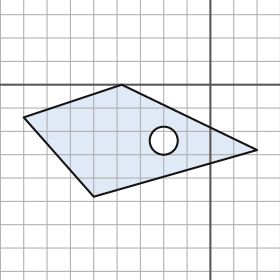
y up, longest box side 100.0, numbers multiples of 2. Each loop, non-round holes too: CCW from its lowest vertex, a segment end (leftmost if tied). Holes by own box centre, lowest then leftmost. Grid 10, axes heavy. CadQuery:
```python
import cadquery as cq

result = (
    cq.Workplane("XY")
    .moveTo(-50.0, -48.0)
    .lineTo(20.0, -28.0)
    .lineTo(-38.0, 0.0)
    .lineTo(-80.0, -14.0)
    .close()
    .moveTo(-20.0, -24.0)
    .circle(6.0)
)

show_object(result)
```